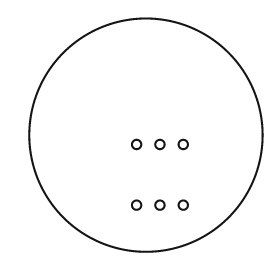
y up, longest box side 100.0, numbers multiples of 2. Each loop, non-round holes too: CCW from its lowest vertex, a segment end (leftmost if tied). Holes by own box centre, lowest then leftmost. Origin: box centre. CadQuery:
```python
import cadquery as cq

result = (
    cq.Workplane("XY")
    .moveTo(0.0, 0.0)
    .circle(50.0)
    .moveTo(-4.0, -30.0)
    .circle(2.0)
    .moveTo(6.0, -30.0)
    .circle(2.0)
    .moveTo(16.0, -30.0)
    .circle(2.0)
    .moveTo(-4.0, -4.0)
    .circle(2.0)
    .moveTo(6.0, -4.0)
    .circle(2.0)
    .moveTo(16.0, -4.0)
    .circle(2.0)
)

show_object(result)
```